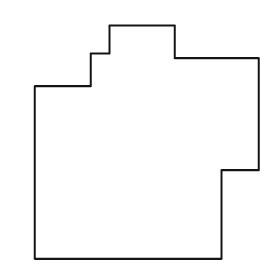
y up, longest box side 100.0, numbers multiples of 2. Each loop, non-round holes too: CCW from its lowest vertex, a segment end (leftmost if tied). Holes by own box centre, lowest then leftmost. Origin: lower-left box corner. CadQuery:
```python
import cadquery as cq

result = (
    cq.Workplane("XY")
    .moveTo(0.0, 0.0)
    .lineTo(80.0, 0.0)
    .lineTo(80.0, 38.0)
    .lineTo(96.0, 38.0)
    .lineTo(96.0, 86.0)
    .lineTo(60.0, 86.0)
    .lineTo(60.0, 100.0)
    .lineTo(32.0, 100.0)
    .lineTo(32.0, 88.0)
    .lineTo(24.0, 88.0)
    .lineTo(24.0, 74.0)
    .lineTo(0.0, 74.0)
    .close()
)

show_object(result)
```